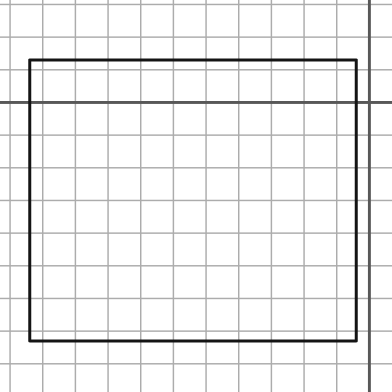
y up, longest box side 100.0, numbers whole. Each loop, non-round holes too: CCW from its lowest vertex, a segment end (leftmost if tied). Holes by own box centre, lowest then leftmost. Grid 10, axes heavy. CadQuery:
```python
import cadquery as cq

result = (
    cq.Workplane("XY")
    .moveTo(-104.0, -73.0)
    .lineTo(-4.0, -73.0)
    .lineTo(-4.0, 13.0)
    .lineTo(-104.0, 13.0)
    .close()
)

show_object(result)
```